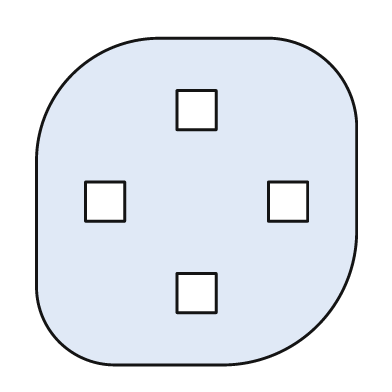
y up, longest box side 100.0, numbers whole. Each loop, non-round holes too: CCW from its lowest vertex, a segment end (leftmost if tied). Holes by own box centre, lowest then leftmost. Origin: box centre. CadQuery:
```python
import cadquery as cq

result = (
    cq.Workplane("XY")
    .moveTo(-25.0, -50.0)
    .lineTo(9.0, -50.0)
    .threePointArc((37.0, -38.0), (49.0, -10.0))
    .lineTo(49.0, 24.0)
    .threePointArc((41.0, 42.0), (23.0, 50.0))
    .lineTo(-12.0, 50.0)
    .threePointArc((-38.0, 39.0), (-49.0, 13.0))
    .lineTo(-49.0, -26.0)
    .threePointArc((-42.0, -43.0), (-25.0, -50.0))
    .close()
    .moveTo(-6.0, -34.0)
    .lineTo(6.0, -34.0)
    .lineTo(6.0, -22.0)
    .lineTo(-6.0, -22.0)
    .close()
    .moveTo(-34.0, -6.0)
    .lineTo(-22.0, -6.0)
    .lineTo(-22.0, 6.0)
    .lineTo(-34.0, 6.0)
    .close()
    .moveTo(22.0, -6.0)
    .lineTo(34.0, -6.0)
    .lineTo(34.0, 6.0)
    .lineTo(22.0, 6.0)
    .close()
    .moveTo(-6.0, 22.0)
    .lineTo(6.0, 22.0)
    .lineTo(6.0, 34.0)
    .lineTo(-6.0, 34.0)
    .close()
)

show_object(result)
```